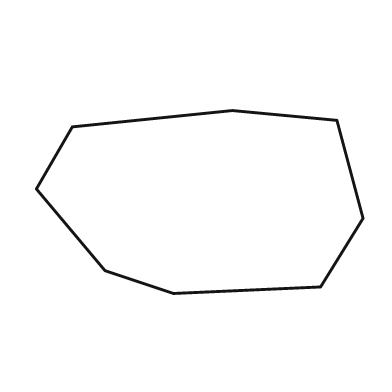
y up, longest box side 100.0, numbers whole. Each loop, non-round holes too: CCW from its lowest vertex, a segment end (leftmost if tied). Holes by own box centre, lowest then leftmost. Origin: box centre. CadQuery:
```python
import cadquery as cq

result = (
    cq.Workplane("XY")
    .moveTo(-8.0, -28.0)
    .lineTo(37.0, -26.0)
    .lineTo(50.0, -5.0)
    .lineTo(42.0, 25.0)
    .lineTo(10.0, 28.0)
    .lineTo(-39.0, 23.0)
    .lineTo(-50.0, 4.0)
    .lineTo(-29.0, -21.0)
    .close()
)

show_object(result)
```